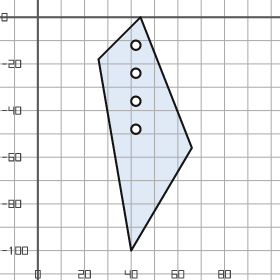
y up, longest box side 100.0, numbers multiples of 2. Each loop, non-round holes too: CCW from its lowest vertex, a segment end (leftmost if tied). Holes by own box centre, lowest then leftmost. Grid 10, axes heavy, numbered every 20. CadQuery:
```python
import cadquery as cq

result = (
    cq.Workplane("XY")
    .moveTo(40.0, -100.0)
    .lineTo(66.0, -56.0)
    .lineTo(44.0, 0.0)
    .lineTo(26.0, -18.0)
    .close()
    .moveTo(42.0, -48.0)
    .circle(2.0)
    .moveTo(42.0, -36.0)
    .circle(2.0)
    .moveTo(42.0, -24.0)
    .circle(2.0)
    .moveTo(42.0, -12.0)
    .circle(2.0)
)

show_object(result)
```